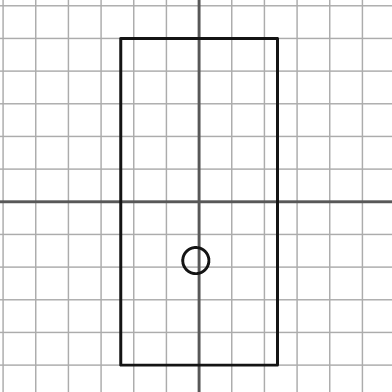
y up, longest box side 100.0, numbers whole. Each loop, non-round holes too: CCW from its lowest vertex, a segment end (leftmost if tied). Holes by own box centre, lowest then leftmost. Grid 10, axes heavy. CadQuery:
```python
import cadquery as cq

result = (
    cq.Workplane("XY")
    .moveTo(-24.0, -50.0)
    .lineTo(24.0, -50.0)
    .lineTo(24.0, 50.0)
    .lineTo(-24.0, 50.0)
    .close()
    .moveTo(-1.0, -18.0)
    .circle(4.0)
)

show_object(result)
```